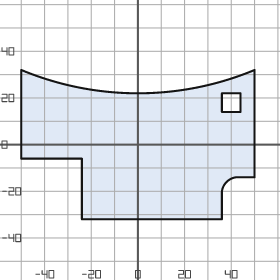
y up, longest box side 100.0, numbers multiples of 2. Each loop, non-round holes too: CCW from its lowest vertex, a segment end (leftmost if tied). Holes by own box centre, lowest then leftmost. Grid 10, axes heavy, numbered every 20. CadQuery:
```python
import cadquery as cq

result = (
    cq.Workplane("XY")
    .moveTo(-24.0, -32.0)
    .lineTo(36.0, -32.0)
    .lineTo(36.0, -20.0)
    .threePointArc((38.0, -16.0), (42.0, -14.0))
    .lineTo(50.0, -14.0)
    .lineTo(50.0, 32.0)
    .threePointArc((0.0, 22.0), (-50.0, 32.0))
    .lineTo(-50.0, -6.0)
    .lineTo(-24.0, -6.0)
    .close()
    .moveTo(36.0, 14.0)
    .lineTo(44.0, 14.0)
    .lineTo(44.0, 22.0)
    .lineTo(36.0, 22.0)
    .close()
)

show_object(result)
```